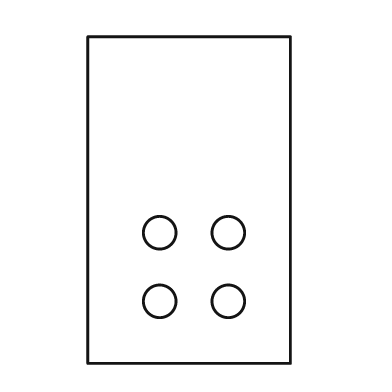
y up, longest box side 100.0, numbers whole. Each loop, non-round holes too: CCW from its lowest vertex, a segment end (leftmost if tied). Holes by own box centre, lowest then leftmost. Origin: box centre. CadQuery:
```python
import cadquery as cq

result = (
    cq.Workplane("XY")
    .moveTo(-31.0, -50.0)
    .lineTo(31.0, -50.0)
    .lineTo(31.0, 50.0)
    .lineTo(-31.0, 50.0)
    .close()
    .moveTo(-9.0, -31.0)
    .circle(5.0)
    .moveTo(12.0, -31.0)
    .circle(5.0)
    .moveTo(-9.0, -10.0)
    .circle(5.0)
    .moveTo(12.0, -10.0)
    .circle(5.0)
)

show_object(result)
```